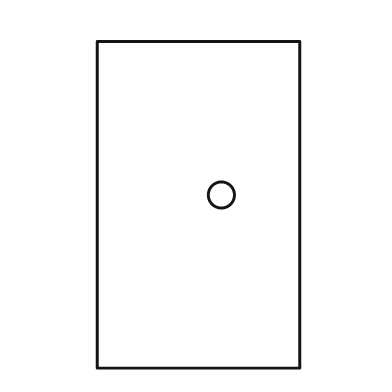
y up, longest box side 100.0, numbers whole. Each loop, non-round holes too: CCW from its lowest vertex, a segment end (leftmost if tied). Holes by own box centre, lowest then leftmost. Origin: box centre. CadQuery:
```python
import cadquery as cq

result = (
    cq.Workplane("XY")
    .moveTo(-31.0, -50.0)
    .lineTo(31.0, -50.0)
    .lineTo(31.0, 50.0)
    .lineTo(-31.0, 50.0)
    .close()
    .moveTo(7.0, 3.0)
    .circle(4.0)
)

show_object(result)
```